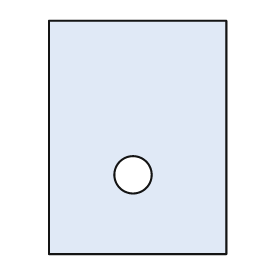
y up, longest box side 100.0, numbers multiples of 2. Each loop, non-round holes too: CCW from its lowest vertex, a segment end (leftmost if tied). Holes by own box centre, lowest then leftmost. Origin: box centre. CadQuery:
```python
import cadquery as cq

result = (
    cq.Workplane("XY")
    .moveTo(-38.0, -50.0)
    .lineTo(38.0, -50.0)
    .lineTo(38.0, 50.0)
    .lineTo(-38.0, 50.0)
    .close()
    .moveTo(-2.0, -16.0)
    .circle(8.0)
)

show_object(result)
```